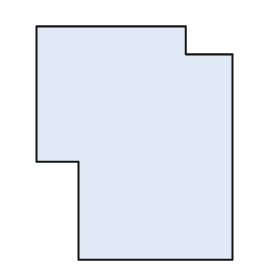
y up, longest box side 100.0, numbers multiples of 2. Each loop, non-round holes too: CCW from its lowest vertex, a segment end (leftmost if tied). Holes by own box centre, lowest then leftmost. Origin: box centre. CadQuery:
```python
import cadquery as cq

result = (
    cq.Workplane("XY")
    .moveTo(-24.0, -50.0)
    .lineTo(42.0, -50.0)
    .lineTo(42.0, 38.0)
    .lineTo(22.0, 38.0)
    .lineTo(22.0, 50.0)
    .lineTo(-42.0, 50.0)
    .lineTo(-42.0, -8.0)
    .lineTo(-24.0, -8.0)
    .close()
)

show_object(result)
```